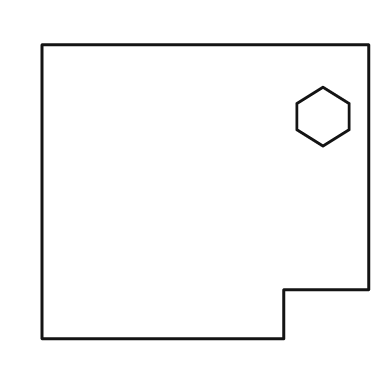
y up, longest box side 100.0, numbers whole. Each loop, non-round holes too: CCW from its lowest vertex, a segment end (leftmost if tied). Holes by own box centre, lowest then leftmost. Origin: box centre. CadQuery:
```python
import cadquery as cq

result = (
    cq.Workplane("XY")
    .moveTo(-50.0, -45.0)
    .lineTo(24.0, -45.0)
    .lineTo(24.0, -30.0)
    .lineTo(50.0, -30.0)
    .lineTo(50.0, 45.0)
    .lineTo(-50.0, 45.0)
    .close()
    .moveTo(36.0, 14.0)
    .lineTo(44.0, 19.0)
    .lineTo(44.0, 27.0)
    .lineTo(36.0, 32.0)
    .lineTo(28.0, 27.0)
    .lineTo(28.0, 19.0)
    .close()
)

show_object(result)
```